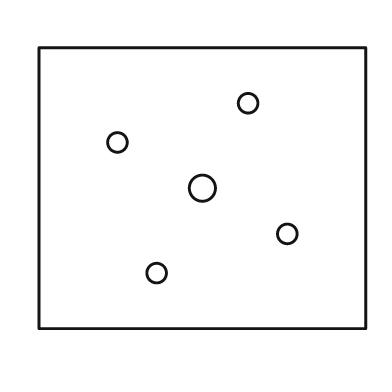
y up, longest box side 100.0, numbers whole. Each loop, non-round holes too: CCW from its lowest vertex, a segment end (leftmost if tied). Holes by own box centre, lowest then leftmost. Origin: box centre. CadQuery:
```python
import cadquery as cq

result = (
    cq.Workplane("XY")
    .moveTo(-50.0, -43.0)
    .lineTo(50.0, -43.0)
    .lineTo(50.0, 43.0)
    .lineTo(-50.0, 43.0)
    .close()
    .moveTo(-14.0, -26.0)
    .circle(3.0)
    .moveTo(26.0, -14.0)
    .circle(3.0)
    .moveTo(0.0, 0.0)
    .circle(4.0)
    .moveTo(-26.0, 14.0)
    .circle(3.0)
    .moveTo(14.0, 26.0)
    .circle(3.0)
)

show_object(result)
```